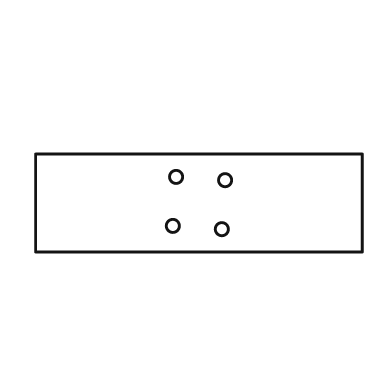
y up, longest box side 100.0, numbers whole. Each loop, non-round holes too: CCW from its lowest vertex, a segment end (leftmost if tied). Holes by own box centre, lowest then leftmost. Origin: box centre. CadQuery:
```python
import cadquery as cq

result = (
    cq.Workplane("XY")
    .moveTo(-50.0, -15.0)
    .lineTo(50.0, -15.0)
    .lineTo(50.0, 15.0)
    .lineTo(-50.0, 15.0)
    .close()
    .moveTo(7.0, -8.0)
    .circle(2.0)
    .moveTo(-8.0, -7.0)
    .circle(2.0)
    .moveTo(8.0, 7.0)
    .circle(2.0)
    .moveTo(-7.0, 8.0)
    .circle(2.0)
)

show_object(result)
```